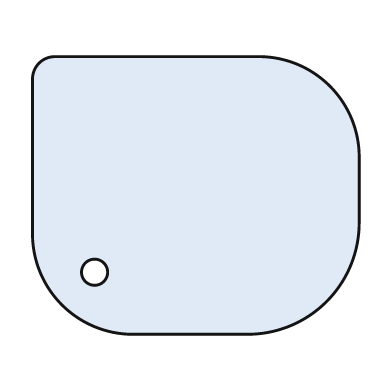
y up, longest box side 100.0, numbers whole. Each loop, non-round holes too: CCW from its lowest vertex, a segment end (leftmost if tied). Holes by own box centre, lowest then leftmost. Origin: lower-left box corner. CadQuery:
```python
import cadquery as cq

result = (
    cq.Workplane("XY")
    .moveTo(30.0, 0.0)
    .lineTo(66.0, 0.0)
    .threePointArc((90.0, 10.0), (100.0, 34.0))
    .lineTo(100.0, 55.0)
    .threePointArc((91.0, 76.0), (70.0, 85.0))
    .lineTo(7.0, 85.0)
    .threePointArc((2.0, 83.0), (0.0, 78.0))
    .lineTo(0.0, 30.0)
    .threePointArc((9.0, 9.0), (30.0, 0.0))
    .close()
    .moveTo(19.0, 19.0)
    .circle(4.0)
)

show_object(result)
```